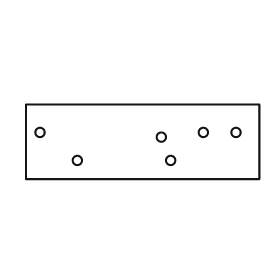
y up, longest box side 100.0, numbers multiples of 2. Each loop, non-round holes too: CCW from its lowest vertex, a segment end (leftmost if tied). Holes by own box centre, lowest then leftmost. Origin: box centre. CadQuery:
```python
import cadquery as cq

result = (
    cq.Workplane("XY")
    .moveTo(-50.0, -16.0)
    .lineTo(50.0, -16.0)
    .lineTo(50.0, 16.0)
    .lineTo(-50.0, 16.0)
    .close()
    .moveTo(-28.0, -8.0)
    .circle(2.0)
    .moveTo(12.0, -8.0)
    .circle(2.0)
    .moveTo(8.0, 2.0)
    .circle(2.0)
    .moveTo(-44.0, 4.0)
    .circle(2.0)
    .moveTo(26.0, 4.0)
    .circle(2.0)
    .moveTo(40.0, 4.0)
    .circle(2.0)
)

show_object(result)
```